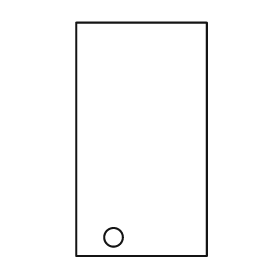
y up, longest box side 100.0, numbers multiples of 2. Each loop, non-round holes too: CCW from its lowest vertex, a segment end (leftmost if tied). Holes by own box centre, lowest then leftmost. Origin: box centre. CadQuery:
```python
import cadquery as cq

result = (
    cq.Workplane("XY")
    .moveTo(-28.0, -50.0)
    .lineTo(28.0, -50.0)
    .lineTo(28.0, 50.0)
    .lineTo(-28.0, 50.0)
    .close()
    .moveTo(-12.0, -42.0)
    .circle(4.0)
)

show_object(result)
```